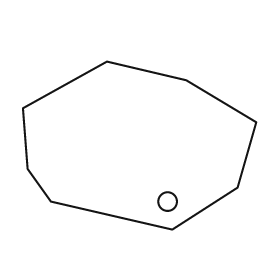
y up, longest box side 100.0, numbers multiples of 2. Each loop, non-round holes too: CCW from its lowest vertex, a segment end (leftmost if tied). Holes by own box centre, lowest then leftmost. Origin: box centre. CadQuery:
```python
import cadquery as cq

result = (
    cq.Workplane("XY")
    .moveTo(14.0, -36.0)
    .lineTo(42.0, -18.0)
    .lineTo(50.0, 10.0)
    .lineTo(20.0, 28.0)
    .lineTo(-14.0, 36.0)
    .lineTo(-50.0, 16.0)
    .lineTo(-48.0, -10.0)
    .lineTo(-38.0, -24.0)
    .close()
    .moveTo(12.0, -24.0)
    .circle(4.0)
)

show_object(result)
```